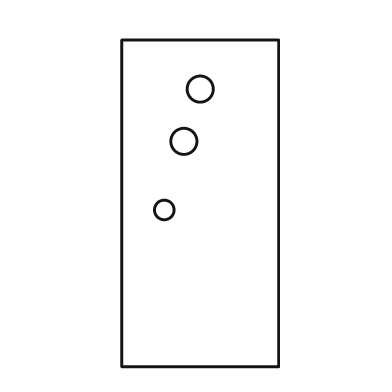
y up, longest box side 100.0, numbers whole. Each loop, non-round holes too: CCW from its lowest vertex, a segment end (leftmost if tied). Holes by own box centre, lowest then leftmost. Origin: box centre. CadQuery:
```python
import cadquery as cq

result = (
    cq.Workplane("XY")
    .moveTo(-24.0, -50.0)
    .lineTo(24.0, -50.0)
    .lineTo(24.0, 50.0)
    .lineTo(-24.0, 50.0)
    .close()
    .moveTo(-11.0, -2.0)
    .circle(3.0)
    .moveTo(-5.0, 19.0)
    .circle(4.0)
    .moveTo(0.0, 35.0)
    .circle(4.0)
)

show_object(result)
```